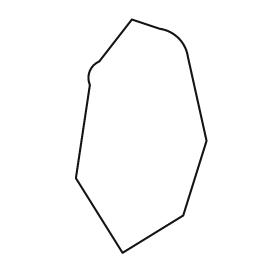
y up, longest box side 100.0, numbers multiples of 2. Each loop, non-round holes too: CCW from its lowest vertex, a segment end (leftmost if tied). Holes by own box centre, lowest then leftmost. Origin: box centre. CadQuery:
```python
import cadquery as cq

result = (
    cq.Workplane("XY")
    .moveTo(-8.0, -50.0)
    .lineTo(18.0, -34.0)
    .lineTo(28.0, -2.0)
    .lineTo(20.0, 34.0)
    .threePointArc((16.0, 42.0), (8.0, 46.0))
    .lineTo(-4.0, 50.0)
    .lineTo(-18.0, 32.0)
    .threePointArc((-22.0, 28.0), (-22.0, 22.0))
    .lineTo(-28.0, -18.0)
    .close()
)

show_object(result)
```